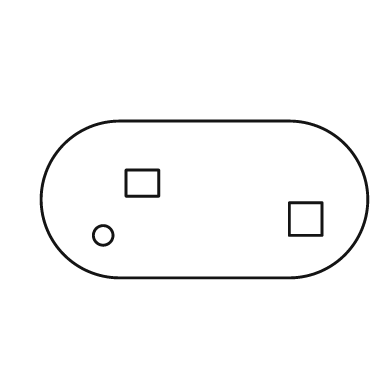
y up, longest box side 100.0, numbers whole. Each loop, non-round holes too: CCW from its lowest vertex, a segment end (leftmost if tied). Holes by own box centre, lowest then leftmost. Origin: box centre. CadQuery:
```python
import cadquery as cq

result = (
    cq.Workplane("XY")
    .moveTo(-26.0, -24.0)
    .lineTo(26.0, -24.0)
    .threePointArc((50.0, 0.0), (26.0, 24.0))
    .lineTo(-26.0, 24.0)
    .threePointArc((-50.0, 0.0), (-26.0, -24.0))
    .close()
    .moveTo(-31.0, -11.0)
    .circle(3.0)
    .moveTo(26.0, -11.0)
    .lineTo(36.0, -11.0)
    .lineTo(36.0, -1.0)
    .lineTo(26.0, -1.0)
    .close()
    .moveTo(-24.0, 1.0)
    .lineTo(-14.0, 1.0)
    .lineTo(-14.0, 9.0)
    .lineTo(-24.0, 9.0)
    .close()
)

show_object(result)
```